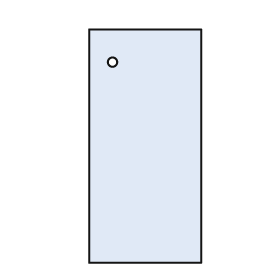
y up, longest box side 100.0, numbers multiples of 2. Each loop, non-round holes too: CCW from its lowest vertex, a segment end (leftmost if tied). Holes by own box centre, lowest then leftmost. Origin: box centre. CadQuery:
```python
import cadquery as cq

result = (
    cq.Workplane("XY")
    .moveTo(-24.0, -50.0)
    .lineTo(24.0, -50.0)
    .lineTo(24.0, 50.0)
    .lineTo(-24.0, 50.0)
    .close()
    .moveTo(-14.0, 36.0)
    .circle(2.0)
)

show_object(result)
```